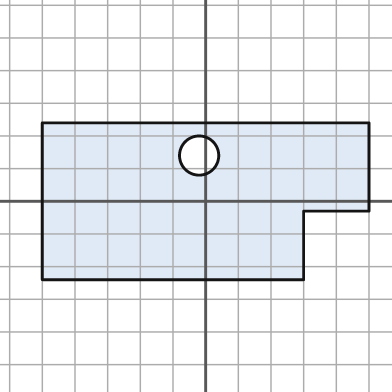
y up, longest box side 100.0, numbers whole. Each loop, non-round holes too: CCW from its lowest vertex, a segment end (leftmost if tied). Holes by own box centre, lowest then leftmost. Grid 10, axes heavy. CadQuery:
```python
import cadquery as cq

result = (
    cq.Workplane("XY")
    .moveTo(-50.0, -24.0)
    .lineTo(30.0, -24.0)
    .lineTo(30.0, -3.0)
    .lineTo(50.0, -3.0)
    .lineTo(50.0, 24.0)
    .lineTo(-50.0, 24.0)
    .close()
    .moveTo(-2.0, 14.0)
    .circle(6.0)
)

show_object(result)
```